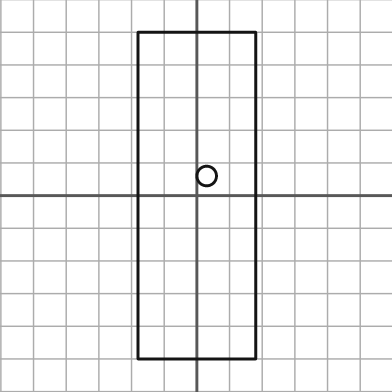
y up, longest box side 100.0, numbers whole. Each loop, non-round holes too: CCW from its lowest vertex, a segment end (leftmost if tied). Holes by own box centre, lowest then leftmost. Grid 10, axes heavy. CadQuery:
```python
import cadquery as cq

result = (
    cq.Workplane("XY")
    .moveTo(-18.0, -50.0)
    .lineTo(18.0, -50.0)
    .lineTo(18.0, 50.0)
    .lineTo(-18.0, 50.0)
    .close()
    .moveTo(3.0, 6.0)
    .circle(3.0)
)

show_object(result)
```